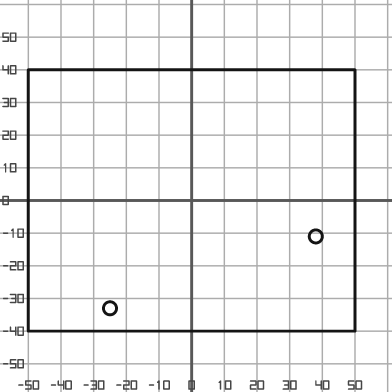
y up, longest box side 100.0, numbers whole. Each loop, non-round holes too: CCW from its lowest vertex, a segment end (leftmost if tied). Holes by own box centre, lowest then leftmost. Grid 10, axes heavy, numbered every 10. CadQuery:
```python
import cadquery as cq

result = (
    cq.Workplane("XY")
    .moveTo(-50.0, -40.0)
    .lineTo(50.0, -40.0)
    .lineTo(50.0, 40.0)
    .lineTo(-50.0, 40.0)
    .close()
    .moveTo(-25.0, -33.0)
    .circle(2.0)
    .moveTo(38.0, -11.0)
    .circle(2.0)
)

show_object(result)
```